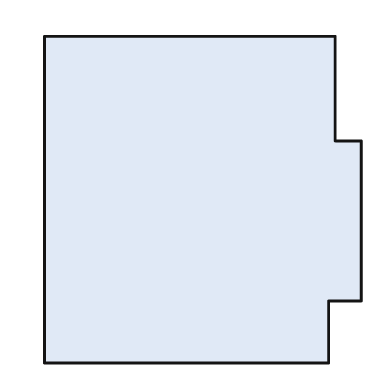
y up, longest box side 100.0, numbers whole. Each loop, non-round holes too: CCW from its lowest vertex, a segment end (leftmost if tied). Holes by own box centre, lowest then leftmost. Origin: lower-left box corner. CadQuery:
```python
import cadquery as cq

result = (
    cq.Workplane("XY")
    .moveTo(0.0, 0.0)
    .lineTo(87.0, 0.0)
    .lineTo(87.0, 19.0)
    .lineTo(97.0, 19.0)
    .lineTo(97.0, 68.0)
    .lineTo(89.0, 68.0)
    .lineTo(89.0, 100.0)
    .lineTo(0.0, 100.0)
    .close()
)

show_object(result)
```